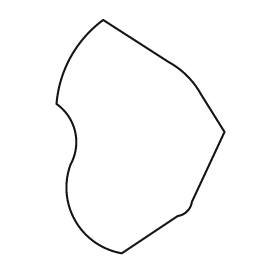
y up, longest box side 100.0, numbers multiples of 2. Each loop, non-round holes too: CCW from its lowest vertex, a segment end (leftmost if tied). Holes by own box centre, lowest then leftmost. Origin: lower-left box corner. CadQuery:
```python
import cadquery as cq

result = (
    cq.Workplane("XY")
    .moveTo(28.0, 0.0)
    .lineTo(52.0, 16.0)
    .threePointArc((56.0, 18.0), (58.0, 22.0))
    .lineTo(72.0, 52.0)
    .lineTo(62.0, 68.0)
    .threePointArc((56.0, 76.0), (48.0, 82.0))
    .lineTo(20.0, 100.0)
    .threePointArc((6.0, 84.0), (0.0, 64.0))
    .threePointArc((8.0, 52.0), (6.0, 38.0))
    .threePointArc((8.0, 14.0), (28.0, 0.0))
    .close()
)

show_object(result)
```